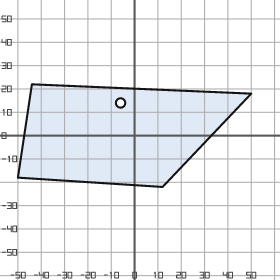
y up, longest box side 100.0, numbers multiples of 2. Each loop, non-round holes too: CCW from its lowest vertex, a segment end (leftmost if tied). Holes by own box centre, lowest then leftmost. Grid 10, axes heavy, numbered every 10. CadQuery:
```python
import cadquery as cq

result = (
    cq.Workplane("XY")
    .moveTo(12.0, -22.0)
    .lineTo(50.0, 18.0)
    .lineTo(-44.0, 22.0)
    .lineTo(-50.0, -18.0)
    .close()
    .moveTo(-6.0, 14.0)
    .circle(2.0)
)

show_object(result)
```